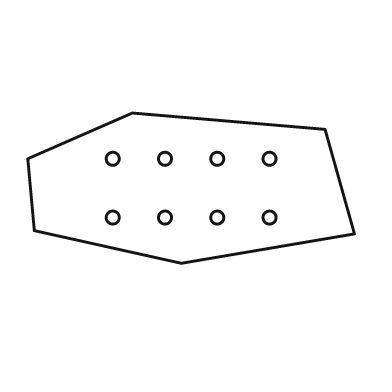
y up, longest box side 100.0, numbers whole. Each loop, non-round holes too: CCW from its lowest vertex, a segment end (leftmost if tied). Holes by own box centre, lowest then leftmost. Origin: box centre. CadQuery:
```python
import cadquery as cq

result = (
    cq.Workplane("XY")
    .moveTo(-3.0, -23.0)
    .lineTo(50.0, -14.0)
    .lineTo(41.0, 18.0)
    .lineTo(-18.0, 23.0)
    .lineTo(-50.0, 9.0)
    .lineTo(-48.0, -13.0)
    .close()
    .moveTo(-24.0, -9.0)
    .circle(2.0)
    .moveTo(-8.0, -9.0)
    .circle(2.0)
    .moveTo(8.0, -9.0)
    .circle(2.0)
    .moveTo(24.0, -9.0)
    .circle(2.0)
    .moveTo(-24.0, 9.0)
    .circle(2.0)
    .moveTo(-8.0, 9.0)
    .circle(2.0)
    .moveTo(8.0, 9.0)
    .circle(2.0)
    .moveTo(24.0, 9.0)
    .circle(2.0)
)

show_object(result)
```